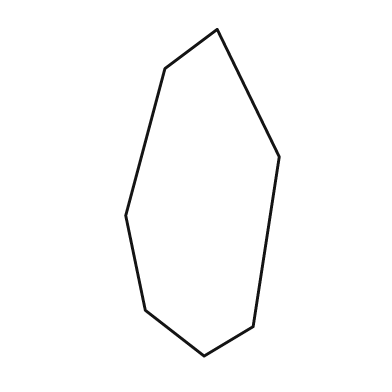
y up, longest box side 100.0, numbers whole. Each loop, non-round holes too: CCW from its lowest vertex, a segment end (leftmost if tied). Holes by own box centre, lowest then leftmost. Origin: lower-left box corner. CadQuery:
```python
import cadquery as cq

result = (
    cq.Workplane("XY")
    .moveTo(24.0, 0.0)
    .lineTo(39.0, 9.0)
    .lineTo(47.0, 61.0)
    .lineTo(28.0, 100.0)
    .lineTo(12.0, 88.0)
    .lineTo(0.0, 43.0)
    .lineTo(6.0, 14.0)
    .close()
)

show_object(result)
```